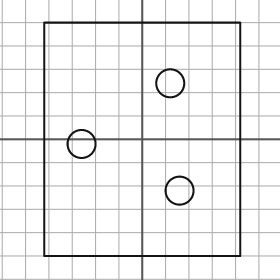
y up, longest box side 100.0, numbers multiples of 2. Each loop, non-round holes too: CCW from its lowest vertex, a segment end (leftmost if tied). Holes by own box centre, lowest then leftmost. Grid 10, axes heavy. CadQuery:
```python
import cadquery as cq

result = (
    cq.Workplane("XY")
    .moveTo(-42.0, -50.0)
    .lineTo(42.0, -50.0)
    .lineTo(42.0, 50.0)
    .lineTo(-42.0, 50.0)
    .close()
    .moveTo(16.0, -22.0)
    .circle(6.0)
    .moveTo(-26.0, -2.0)
    .circle(6.0)
    .moveTo(12.0, 24.0)
    .circle(6.0)
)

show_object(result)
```